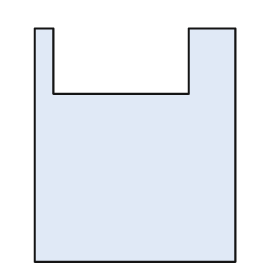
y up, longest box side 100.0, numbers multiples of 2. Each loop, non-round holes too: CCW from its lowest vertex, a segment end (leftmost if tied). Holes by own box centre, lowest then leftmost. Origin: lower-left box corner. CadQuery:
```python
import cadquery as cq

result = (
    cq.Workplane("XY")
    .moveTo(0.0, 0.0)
    .lineTo(86.0, 0.0)
    .lineTo(86.0, 100.0)
    .lineTo(66.0, 100.0)
    .lineTo(66.0, 72.0)
    .lineTo(8.0, 72.0)
    .lineTo(8.0, 100.0)
    .lineTo(0.0, 100.0)
    .close()
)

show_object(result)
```